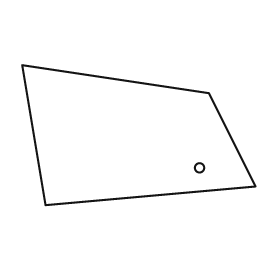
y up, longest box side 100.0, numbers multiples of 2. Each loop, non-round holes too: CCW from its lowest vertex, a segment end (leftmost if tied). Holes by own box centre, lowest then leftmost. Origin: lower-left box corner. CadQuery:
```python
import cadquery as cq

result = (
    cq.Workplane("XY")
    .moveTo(10.0, 0.0)
    .lineTo(100.0, 8.0)
    .lineTo(80.0, 48.0)
    .lineTo(0.0, 60.0)
    .close()
    .moveTo(76.0, 16.0)
    .circle(2.0)
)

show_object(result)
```